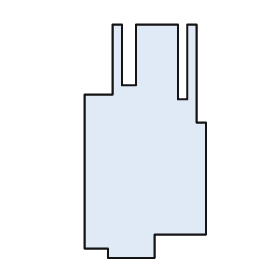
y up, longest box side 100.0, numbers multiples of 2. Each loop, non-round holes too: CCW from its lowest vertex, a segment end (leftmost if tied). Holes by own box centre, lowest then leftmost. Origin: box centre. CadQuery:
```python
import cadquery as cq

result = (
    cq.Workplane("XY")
    .moveTo(-16.0, -50.0)
    .lineTo(4.0, -50.0)
    .lineTo(4.0, -40.0)
    .lineTo(26.0, -40.0)
    .lineTo(26.0, 8.0)
    .lineTo(22.0, 8.0)
    .lineTo(22.0, 50.0)
    .lineTo(18.0, 50.0)
    .lineTo(18.0, 18.0)
    .lineTo(14.0, 18.0)
    .lineTo(14.0, 50.0)
    .lineTo(-4.0, 50.0)
    .lineTo(-4.0, 24.0)
    .lineTo(-10.0, 24.0)
    .lineTo(-10.0, 50.0)
    .lineTo(-14.0, 50.0)
    .lineTo(-14.0, 20.0)
    .lineTo(-26.0, 20.0)
    .lineTo(-26.0, -46.0)
    .lineTo(-16.0, -46.0)
    .close()
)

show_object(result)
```